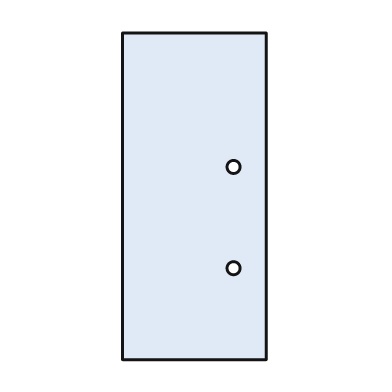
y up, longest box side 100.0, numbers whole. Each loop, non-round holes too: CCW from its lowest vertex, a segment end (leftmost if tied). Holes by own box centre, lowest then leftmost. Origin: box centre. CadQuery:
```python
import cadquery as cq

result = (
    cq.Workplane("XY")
    .moveTo(-22.0, -50.0)
    .lineTo(22.0, -50.0)
    .lineTo(22.0, 50.0)
    .lineTo(-22.0, 50.0)
    .close()
    .moveTo(12.0, -22.0)
    .circle(2.0)
    .moveTo(12.0, 9.0)
    .circle(2.0)
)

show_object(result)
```